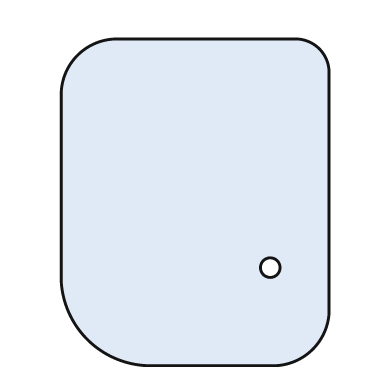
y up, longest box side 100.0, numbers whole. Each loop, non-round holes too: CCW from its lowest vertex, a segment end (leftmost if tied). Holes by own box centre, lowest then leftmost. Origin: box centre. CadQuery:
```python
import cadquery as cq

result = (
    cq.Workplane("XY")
    .moveTo(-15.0, -50.0)
    .lineTo(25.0, -50.0)
    .threePointArc((36.0, -45.0), (41.0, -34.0))
    .lineTo(41.0, 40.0)
    .threePointArc((38.0, 47.0), (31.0, 50.0))
    .lineTo(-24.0, 50.0)
    .threePointArc((-36.0, 45.0), (-41.0, 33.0))
    .lineTo(-41.0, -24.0)
    .threePointArc((-33.0, -42.0), (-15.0, -50.0))
    .close()
    .moveTo(23.0, -20.0)
    .circle(3.0)
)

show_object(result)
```